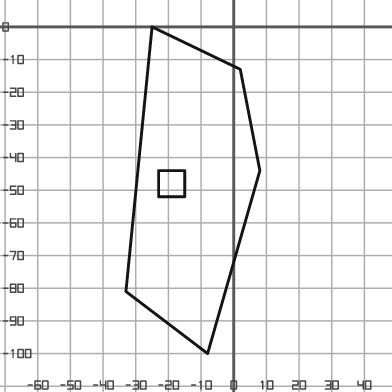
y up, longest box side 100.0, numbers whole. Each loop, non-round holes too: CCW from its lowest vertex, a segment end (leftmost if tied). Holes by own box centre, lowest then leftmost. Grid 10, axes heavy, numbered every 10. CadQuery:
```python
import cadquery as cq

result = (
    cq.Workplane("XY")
    .moveTo(-8.0, -100.0)
    .lineTo(8.0, -44.0)
    .lineTo(2.0, -13.0)
    .lineTo(-25.0, 0.0)
    .lineTo(-33.0, -81.0)
    .close()
    .moveTo(-23.0, -52.0)
    .lineTo(-15.0, -52.0)
    .lineTo(-15.0, -44.0)
    .lineTo(-23.0, -44.0)
    .close()
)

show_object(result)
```